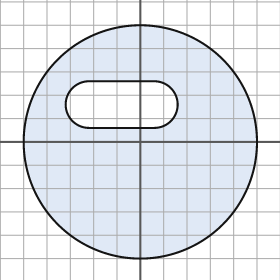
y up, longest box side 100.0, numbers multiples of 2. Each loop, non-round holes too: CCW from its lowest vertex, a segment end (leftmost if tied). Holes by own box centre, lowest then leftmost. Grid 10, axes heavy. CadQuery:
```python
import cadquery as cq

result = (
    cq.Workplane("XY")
    .moveTo(0.0, 0.0)
    .circle(50.0)
    .moveTo(-22.0, 6.0)
    .lineTo(6.0, 6.0)
    .threePointArc((16.0, 16.0), (6.0, 26.0))
    .lineTo(-22.0, 26.0)
    .threePointArc((-32.0, 16.0), (-22.0, 6.0))
    .close()
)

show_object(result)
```